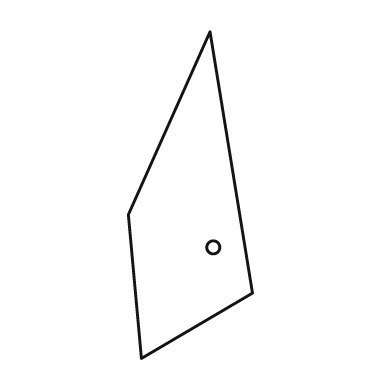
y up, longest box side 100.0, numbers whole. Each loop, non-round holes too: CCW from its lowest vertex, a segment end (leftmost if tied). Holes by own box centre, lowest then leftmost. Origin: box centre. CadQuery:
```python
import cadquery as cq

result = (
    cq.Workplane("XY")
    .moveTo(-15.0, -50.0)
    .lineTo(19.0, -30.0)
    .lineTo(6.0, 50.0)
    .lineTo(-19.0, -6.0)
    .close()
    .moveTo(7.0, -16.0)
    .circle(2.0)
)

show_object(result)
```